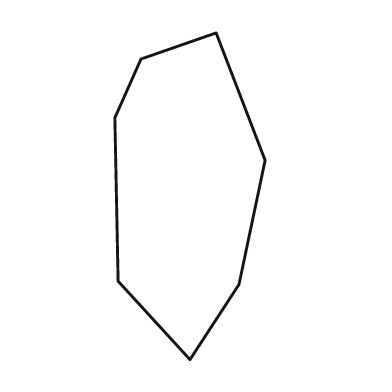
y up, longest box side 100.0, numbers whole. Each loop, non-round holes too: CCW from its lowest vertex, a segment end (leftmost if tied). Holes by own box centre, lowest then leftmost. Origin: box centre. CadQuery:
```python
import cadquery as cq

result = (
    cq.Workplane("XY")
    .moveTo(0.0, -50.0)
    .lineTo(15.0, -27.0)
    .lineTo(23.0, 11.0)
    .lineTo(8.0, 50.0)
    .lineTo(-15.0, 42.0)
    .lineTo(-23.0, 24.0)
    .lineTo(-22.0, -26.0)
    .close()
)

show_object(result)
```